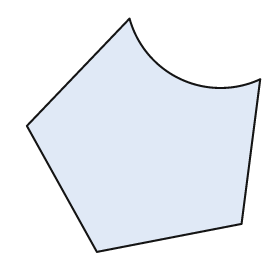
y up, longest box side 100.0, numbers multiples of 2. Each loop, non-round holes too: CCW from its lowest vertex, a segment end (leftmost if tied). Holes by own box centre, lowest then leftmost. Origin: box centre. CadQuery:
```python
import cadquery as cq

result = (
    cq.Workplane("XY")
    .moveTo(-20.0, -50.0)
    .lineTo(42.0, -38.0)
    .lineTo(50.0, 24.0)
    .threePointArc((16.0, 24.0), (-6.0, 50.0))
    .lineTo(-50.0, 4.0)
    .close()
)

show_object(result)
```